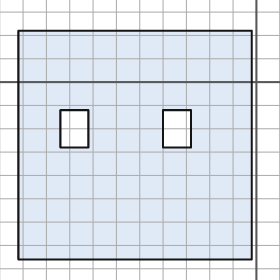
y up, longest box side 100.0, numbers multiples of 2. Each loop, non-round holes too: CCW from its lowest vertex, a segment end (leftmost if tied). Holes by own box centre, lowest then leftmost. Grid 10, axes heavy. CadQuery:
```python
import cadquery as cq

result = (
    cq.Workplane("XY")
    .moveTo(-102.0, -76.0)
    .lineTo(-2.0, -76.0)
    .lineTo(-2.0, 22.0)
    .lineTo(-102.0, 22.0)
    .close()
    .moveTo(-84.0, -28.0)
    .lineTo(-72.0, -28.0)
    .lineTo(-72.0, -12.0)
    .lineTo(-84.0, -12.0)
    .close()
    .moveTo(-40.0, -28.0)
    .lineTo(-28.0, -28.0)
    .lineTo(-28.0, -12.0)
    .lineTo(-40.0, -12.0)
    .close()
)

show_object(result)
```